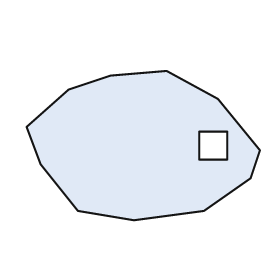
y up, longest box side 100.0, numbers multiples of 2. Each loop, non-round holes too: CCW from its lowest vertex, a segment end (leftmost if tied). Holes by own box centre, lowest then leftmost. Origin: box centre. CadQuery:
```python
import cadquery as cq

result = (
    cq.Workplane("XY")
    .moveTo(-4.0, -32.0)
    .lineTo(26.0, -28.0)
    .lineTo(46.0, -14.0)
    .lineTo(50.0, -2.0)
    .lineTo(32.0, 20.0)
    .lineTo(10.0, 32.0)
    .lineTo(-14.0, 30.0)
    .lineTo(-32.0, 24.0)
    .lineTo(-50.0, 8.0)
    .lineTo(-44.0, -8.0)
    .lineTo(-28.0, -28.0)
    .close()
    .moveTo(24.0, -6.0)
    .lineTo(36.0, -6.0)
    .lineTo(36.0, 6.0)
    .lineTo(24.0, 6.0)
    .close()
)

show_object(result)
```